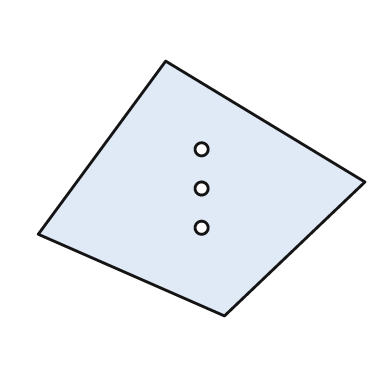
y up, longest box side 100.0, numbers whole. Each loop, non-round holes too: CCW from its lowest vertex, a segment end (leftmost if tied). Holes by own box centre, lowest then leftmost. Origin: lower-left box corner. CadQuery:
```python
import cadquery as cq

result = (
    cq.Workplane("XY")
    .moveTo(57.0, 0.0)
    .lineTo(100.0, 41.0)
    .lineTo(39.0, 78.0)
    .lineTo(0.0, 25.0)
    .close()
    .moveTo(50.0, 27.0)
    .circle(2.0)
    .moveTo(50.0, 39.0)
    .circle(2.0)
    .moveTo(50.0, 51.0)
    .circle(2.0)
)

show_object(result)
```